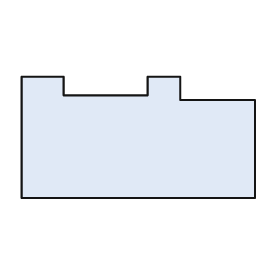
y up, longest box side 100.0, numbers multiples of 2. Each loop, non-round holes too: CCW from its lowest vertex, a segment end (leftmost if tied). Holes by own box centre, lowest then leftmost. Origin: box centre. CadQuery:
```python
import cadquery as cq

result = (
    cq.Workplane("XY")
    .moveTo(-50.0, -26.0)
    .lineTo(50.0, -26.0)
    .lineTo(50.0, 16.0)
    .lineTo(18.0, 16.0)
    .lineTo(18.0, 26.0)
    .lineTo(4.0, 26.0)
    .lineTo(4.0, 18.0)
    .lineTo(-32.0, 18.0)
    .lineTo(-32.0, 26.0)
    .lineTo(-50.0, 26.0)
    .close()
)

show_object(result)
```